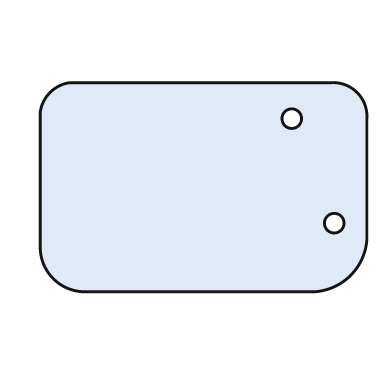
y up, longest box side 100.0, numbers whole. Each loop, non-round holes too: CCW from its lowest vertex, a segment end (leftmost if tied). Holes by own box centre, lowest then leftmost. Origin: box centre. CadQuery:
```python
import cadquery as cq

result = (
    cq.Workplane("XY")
    .moveTo(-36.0, -32.0)
    .lineTo(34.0, -32.0)
    .threePointArc((45.0, -27.0), (50.0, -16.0))
    .lineTo(50.0, 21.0)
    .threePointArc((47.0, 29.0), (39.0, 32.0))
    .lineTo(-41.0, 32.0)
    .threePointArc((-47.0, 29.0), (-50.0, 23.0))
    .lineTo(-50.0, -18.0)
    .threePointArc((-46.0, -28.0), (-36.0, -32.0))
    .close()
    .moveTo(40.0, -11.0)
    .circle(3.0)
    .moveTo(27.0, 21.0)
    .circle(3.0)
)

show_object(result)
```